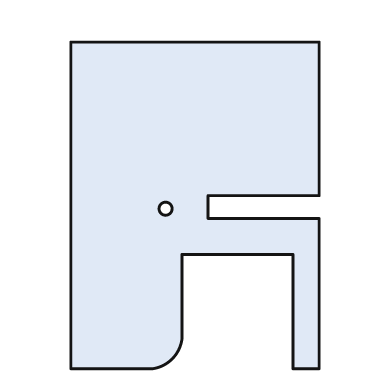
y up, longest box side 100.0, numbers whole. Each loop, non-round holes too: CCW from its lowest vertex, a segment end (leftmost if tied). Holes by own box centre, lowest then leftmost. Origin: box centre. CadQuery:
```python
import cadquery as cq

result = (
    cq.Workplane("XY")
    .moveTo(-38.0, -50.0)
    .lineTo(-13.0, -50.0)
    .threePointArc((-7.0, -47.0), (-4.0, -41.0))
    .lineTo(-4.0, -15.0)
    .lineTo(30.0, -15.0)
    .lineTo(30.0, -50.0)
    .lineTo(38.0, -50.0)
    .lineTo(38.0, -4.0)
    .lineTo(4.0, -4.0)
    .lineTo(4.0, 3.0)
    .lineTo(38.0, 3.0)
    .lineTo(38.0, 50.0)
    .lineTo(-38.0, 50.0)
    .close()
    .moveTo(-9.0, -1.0)
    .circle(2.0)
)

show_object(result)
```